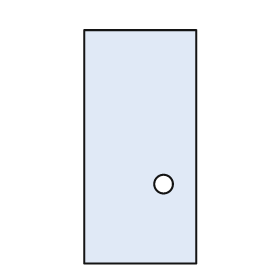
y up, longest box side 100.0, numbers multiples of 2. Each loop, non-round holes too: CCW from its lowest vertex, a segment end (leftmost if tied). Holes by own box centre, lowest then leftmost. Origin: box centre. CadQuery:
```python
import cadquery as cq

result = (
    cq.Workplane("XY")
    .moveTo(-24.0, -50.0)
    .lineTo(24.0, -50.0)
    .lineTo(24.0, 50.0)
    .lineTo(-24.0, 50.0)
    .close()
    .moveTo(10.0, -16.0)
    .circle(4.0)
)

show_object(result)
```